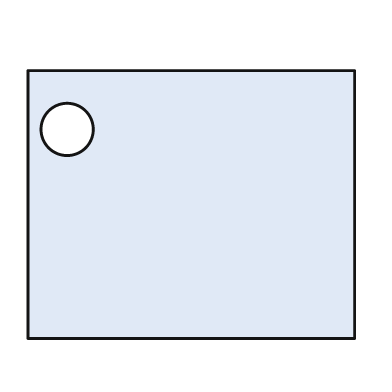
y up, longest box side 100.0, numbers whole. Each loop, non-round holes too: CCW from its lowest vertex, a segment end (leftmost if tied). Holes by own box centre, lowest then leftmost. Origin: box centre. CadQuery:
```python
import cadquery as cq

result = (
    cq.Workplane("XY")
    .moveTo(-50.0, -41.0)
    .lineTo(50.0, -41.0)
    .lineTo(50.0, 41.0)
    .lineTo(-50.0, 41.0)
    .close()
    .moveTo(-38.0, 23.0)
    .circle(8.0)
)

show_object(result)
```